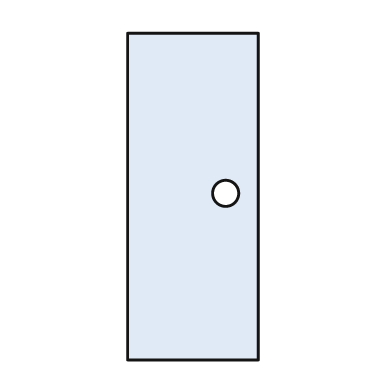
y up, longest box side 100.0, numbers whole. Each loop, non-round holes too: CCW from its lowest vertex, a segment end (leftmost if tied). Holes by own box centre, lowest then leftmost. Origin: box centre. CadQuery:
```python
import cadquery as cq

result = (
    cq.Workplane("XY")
    .moveTo(-20.0, -50.0)
    .lineTo(20.0, -50.0)
    .lineTo(20.0, 50.0)
    .lineTo(-20.0, 50.0)
    .close()
    .moveTo(10.0, 1.0)
    .circle(4.0)
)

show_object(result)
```